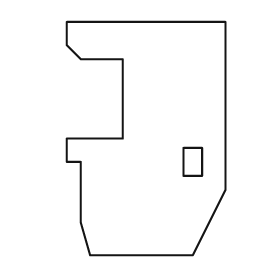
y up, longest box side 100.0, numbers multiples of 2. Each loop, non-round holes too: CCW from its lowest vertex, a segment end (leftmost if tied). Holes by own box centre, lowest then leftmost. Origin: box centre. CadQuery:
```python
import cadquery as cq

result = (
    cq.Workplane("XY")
    .moveTo(-24.0, -50.0)
    .lineTo(20.0, -50.0)
    .lineTo(34.0, -22.0)
    .lineTo(34.0, 50.0)
    .lineTo(-34.0, 50.0)
    .lineTo(-34.0, 40.0)
    .lineTo(-28.0, 34.0)
    .lineTo(-10.0, 34.0)
    .lineTo(-10.0, 0.0)
    .lineTo(-34.0, 0.0)
    .lineTo(-34.0, -10.0)
    .lineTo(-28.0, -10.0)
    .lineTo(-28.0, -36.0)
    .close()
    .moveTo(16.0, -16.0)
    .lineTo(24.0, -16.0)
    .lineTo(24.0, -4.0)
    .lineTo(16.0, -4.0)
    .close()
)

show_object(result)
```